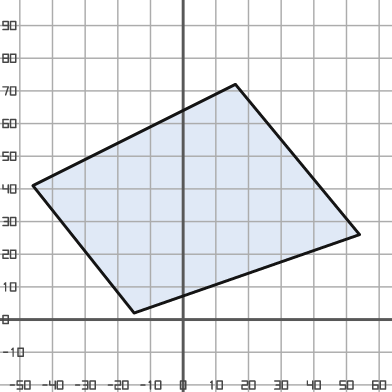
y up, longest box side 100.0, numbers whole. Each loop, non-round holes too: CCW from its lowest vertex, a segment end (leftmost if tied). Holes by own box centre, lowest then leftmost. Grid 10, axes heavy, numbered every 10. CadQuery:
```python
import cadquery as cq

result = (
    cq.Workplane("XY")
    .moveTo(-15.0, 2.0)
    .lineTo(54.0, 26.0)
    .lineTo(16.0, 72.0)
    .lineTo(-46.0, 41.0)
    .close()
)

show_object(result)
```